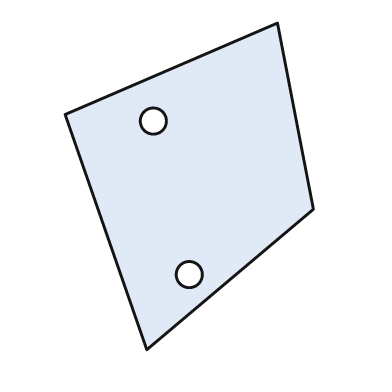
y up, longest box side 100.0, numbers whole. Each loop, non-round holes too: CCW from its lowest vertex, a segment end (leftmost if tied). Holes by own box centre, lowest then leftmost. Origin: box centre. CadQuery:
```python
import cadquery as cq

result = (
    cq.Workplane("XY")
    .moveTo(-13.0, -50.0)
    .lineTo(38.0, -7.0)
    .lineTo(27.0, 50.0)
    .lineTo(-38.0, 22.0)
    .close()
    .moveTo(0.0, -27.0)
    .circle(4.0)
    .moveTo(-11.0, 20.0)
    .circle(4.0)
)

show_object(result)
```